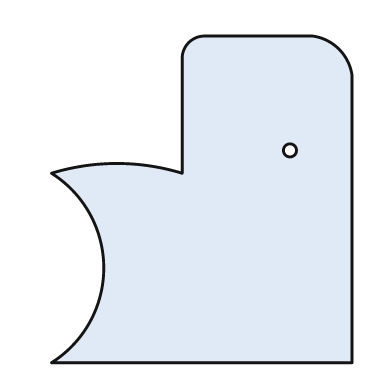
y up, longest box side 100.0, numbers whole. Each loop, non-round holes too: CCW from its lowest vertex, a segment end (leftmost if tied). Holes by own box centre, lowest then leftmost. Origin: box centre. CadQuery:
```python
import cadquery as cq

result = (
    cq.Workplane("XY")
    .moveTo(-46.0, -50.0)
    .lineTo(46.0, -50.0)
    .lineTo(46.0, 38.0)
    .threePointArc((42.0, 46.0), (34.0, 50.0))
    .lineTo(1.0, 50.0)
    .threePointArc((-4.0, 48.0), (-6.0, 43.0))
    .lineTo(-6.0, 8.0)
    .threePointArc((-26.0, 11.0), (-46.0, 8.0))
    .threePointArc((-30.0, -21.0), (-46.0, -50.0))
    .close()
    .moveTo(27.0, 15.0)
    .circle(2.0)
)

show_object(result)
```